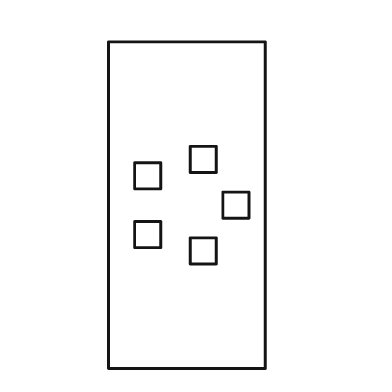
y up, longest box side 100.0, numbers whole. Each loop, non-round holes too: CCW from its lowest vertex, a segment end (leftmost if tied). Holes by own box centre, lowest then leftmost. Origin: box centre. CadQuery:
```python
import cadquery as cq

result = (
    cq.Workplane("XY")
    .moveTo(-24.0, -50.0)
    .lineTo(24.0, -50.0)
    .lineTo(24.0, 50.0)
    .lineTo(-24.0, 50.0)
    .close()
    .moveTo(1.0, -18.0)
    .lineTo(9.0, -18.0)
    .lineTo(9.0, -10.0)
    .lineTo(1.0, -10.0)
    .close()
    .moveTo(-16.0, -13.0)
    .lineTo(-8.0, -13.0)
    .lineTo(-8.0, -5.0)
    .lineTo(-16.0, -5.0)
    .close()
    .moveTo(11.0, -4.0)
    .lineTo(19.0, -4.0)
    .lineTo(19.0, 4.0)
    .lineTo(11.0, 4.0)
    .close()
    .moveTo(-16.0, 5.0)
    .lineTo(-8.0, 5.0)
    .lineTo(-8.0, 13.0)
    .lineTo(-16.0, 13.0)
    .close()
    .moveTo(1.0, 10.0)
    .lineTo(9.0, 10.0)
    .lineTo(9.0, 18.0)
    .lineTo(1.0, 18.0)
    .close()
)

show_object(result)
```